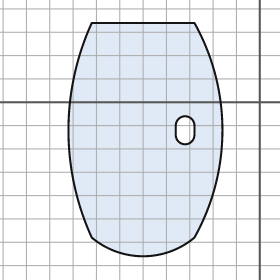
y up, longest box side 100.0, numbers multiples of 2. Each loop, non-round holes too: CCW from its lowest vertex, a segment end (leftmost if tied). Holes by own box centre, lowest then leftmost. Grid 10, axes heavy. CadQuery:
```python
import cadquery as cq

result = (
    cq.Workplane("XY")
    .moveTo(-72.0, -58.0)
    .threePointArc((-50.0, -66.0), (-28.0, -58.0))
    .threePointArc((-16.0, -12.0), (-28.0, 34.0))
    .lineTo(-72.0, 34.0)
    .threePointArc((-82.0, -12.0), (-72.0, -58.0))
    .close()
    .moveTo(-36.0, -14.0)
    .threePointArc((-32.0, -18.0), (-28.0, -14.0))
    .lineTo(-28.0, -10.0)
    .threePointArc((-32.0, -6.0), (-36.0, -10.0))
    .close()
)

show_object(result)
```